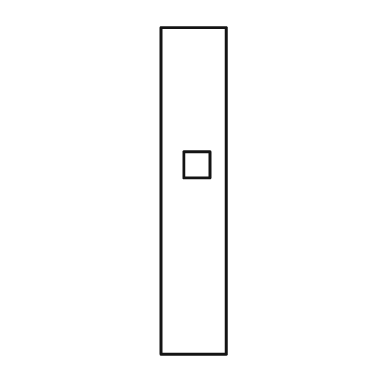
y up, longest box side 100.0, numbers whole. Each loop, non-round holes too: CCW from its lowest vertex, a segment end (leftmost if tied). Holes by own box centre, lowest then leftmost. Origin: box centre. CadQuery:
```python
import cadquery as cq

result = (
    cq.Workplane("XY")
    .moveTo(-10.0, -50.0)
    .lineTo(10.0, -50.0)
    .lineTo(10.0, 50.0)
    .lineTo(-10.0, 50.0)
    .close()
    .moveTo(-3.0, 4.0)
    .lineTo(5.0, 4.0)
    .lineTo(5.0, 12.0)
    .lineTo(-3.0, 12.0)
    .close()
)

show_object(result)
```